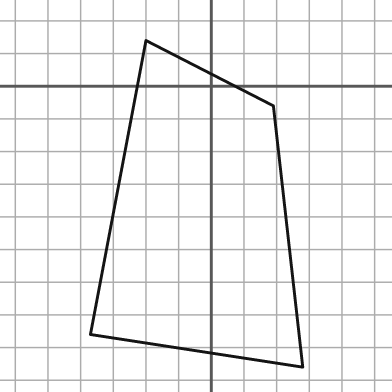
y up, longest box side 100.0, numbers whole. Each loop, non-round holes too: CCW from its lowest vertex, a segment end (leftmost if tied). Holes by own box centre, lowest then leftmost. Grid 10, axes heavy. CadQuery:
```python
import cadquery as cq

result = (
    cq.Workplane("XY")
    .moveTo(28.0, -86.0)
    .lineTo(19.0, -6.0)
    .lineTo(-20.0, 14.0)
    .lineTo(-37.0, -76.0)
    .close()
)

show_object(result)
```